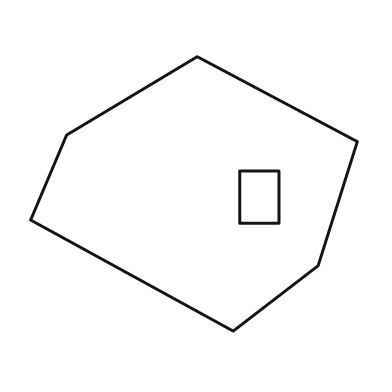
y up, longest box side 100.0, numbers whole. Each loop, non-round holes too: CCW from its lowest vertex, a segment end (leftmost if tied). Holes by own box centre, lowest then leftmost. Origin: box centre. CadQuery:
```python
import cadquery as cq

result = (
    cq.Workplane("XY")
    .moveTo(12.0, -42.0)
    .lineTo(38.0, -22.0)
    .lineTo(50.0, 16.0)
    .lineTo(1.0, 42.0)
    .lineTo(-39.0, 18.0)
    .lineTo(-50.0, -8.0)
    .close()
    .moveTo(14.0, -9.0)
    .lineTo(26.0, -9.0)
    .lineTo(26.0, 7.0)
    .lineTo(14.0, 7.0)
    .close()
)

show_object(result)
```